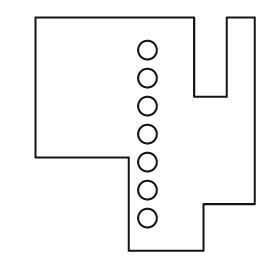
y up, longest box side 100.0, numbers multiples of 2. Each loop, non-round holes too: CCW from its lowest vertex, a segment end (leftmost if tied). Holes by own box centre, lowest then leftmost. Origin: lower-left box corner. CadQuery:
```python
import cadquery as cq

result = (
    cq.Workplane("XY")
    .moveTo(40.0, 0.0)
    .lineTo(72.0, 0.0)
    .lineTo(72.0, 20.0)
    .lineTo(94.0, 20.0)
    .lineTo(94.0, 100.0)
    .lineTo(82.0, 100.0)
    .lineTo(82.0, 66.0)
    .lineTo(68.0, 66.0)
    .lineTo(68.0, 100.0)
    .lineTo(0.0, 100.0)
    .lineTo(0.0, 40.0)
    .lineTo(40.0, 40.0)
    .close()
    .moveTo(48.0, 14.0)
    .circle(4.0)
    .moveTo(48.0, 26.0)
    .circle(4.0)
    .moveTo(48.0, 38.0)
    .circle(4.0)
    .moveTo(48.0, 50.0)
    .circle(4.0)
    .moveTo(48.0, 62.0)
    .circle(4.0)
    .moveTo(48.0, 74.0)
    .circle(4.0)
    .moveTo(48.0, 86.0)
    .circle(4.0)
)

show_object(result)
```